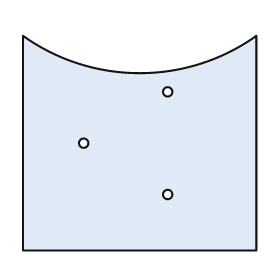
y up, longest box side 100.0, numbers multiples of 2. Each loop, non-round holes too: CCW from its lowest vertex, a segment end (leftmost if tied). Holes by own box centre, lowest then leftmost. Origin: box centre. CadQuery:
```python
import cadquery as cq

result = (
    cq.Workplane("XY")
    .moveTo(-50.0, -46.0)
    .lineTo(50.0, -46.0)
    .lineTo(50.0, 46.0)
    .threePointArc((0.0, 30.0), (-50.0, 46.0))
    .close()
    .moveTo(12.0, -22.0)
    .circle(2.0)
    .moveTo(-24.0, 0.0)
    .circle(2.0)
    .moveTo(12.0, 22.0)
    .circle(2.0)
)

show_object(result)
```